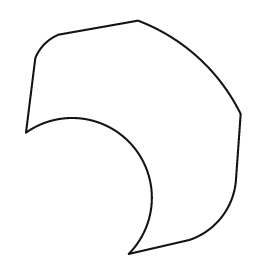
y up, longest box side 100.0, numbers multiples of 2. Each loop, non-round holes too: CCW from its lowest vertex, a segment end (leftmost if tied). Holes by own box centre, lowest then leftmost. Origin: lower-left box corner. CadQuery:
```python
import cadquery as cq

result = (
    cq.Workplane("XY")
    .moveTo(44.0, 0.0)
    .lineTo(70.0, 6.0)
    .threePointArc((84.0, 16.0), (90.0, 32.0))
    .lineTo(92.0, 60.0)
    .threePointArc((74.0, 84.0), (48.0, 100.0))
    .lineTo(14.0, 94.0)
    .threePointArc((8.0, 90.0), (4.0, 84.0))
    .lineTo(0.0, 52.0)
    .threePointArc((46.0, 46.0), (44.0, 0.0))
    .close()
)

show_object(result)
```